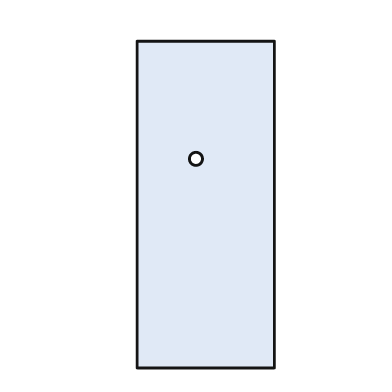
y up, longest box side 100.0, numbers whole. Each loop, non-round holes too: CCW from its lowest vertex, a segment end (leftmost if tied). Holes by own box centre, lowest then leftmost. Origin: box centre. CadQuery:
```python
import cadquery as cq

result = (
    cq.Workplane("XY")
    .moveTo(-21.0, -50.0)
    .lineTo(21.0, -50.0)
    .lineTo(21.0, 50.0)
    .lineTo(-21.0, 50.0)
    .close()
    .moveTo(-3.0, 14.0)
    .circle(2.0)
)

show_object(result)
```